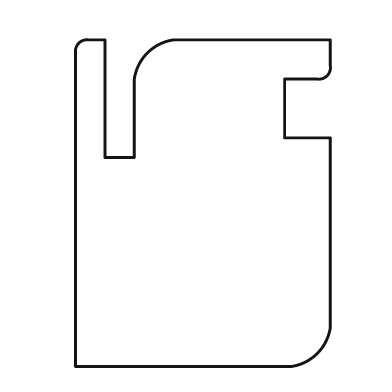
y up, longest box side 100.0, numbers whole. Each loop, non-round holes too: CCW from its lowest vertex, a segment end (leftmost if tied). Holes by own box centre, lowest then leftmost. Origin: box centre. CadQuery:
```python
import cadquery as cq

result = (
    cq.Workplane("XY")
    .moveTo(-39.0, -50.0)
    .lineTo(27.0, -50.0)
    .threePointArc((35.0, -46.0), (39.0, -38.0))
    .lineTo(39.0, 20.0)
    .lineTo(25.0, 20.0)
    .lineTo(25.0, 38.0)
    .lineTo(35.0, 38.0)
    .threePointArc((38.0, 39.0), (39.0, 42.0))
    .lineTo(39.0, 50.0)
    .lineTo(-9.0, 50.0)
    .threePointArc((-17.0, 46.0), (-21.0, 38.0))
    .lineTo(-21.0, 14.0)
    .lineTo(-30.0, 14.0)
    .lineTo(-30.0, 50.0)
    .lineTo(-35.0, 50.0)
    .threePointArc((-38.0, 49.0), (-39.0, 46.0))
    .close()
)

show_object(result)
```